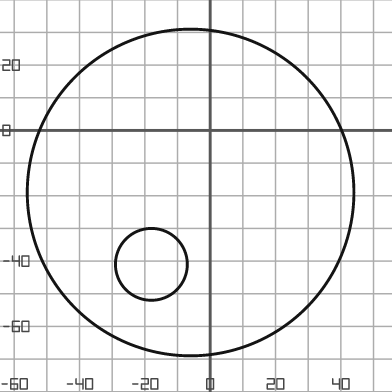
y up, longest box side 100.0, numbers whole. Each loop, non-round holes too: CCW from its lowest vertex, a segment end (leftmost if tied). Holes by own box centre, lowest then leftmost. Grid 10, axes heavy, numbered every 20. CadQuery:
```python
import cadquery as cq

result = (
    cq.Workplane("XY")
    .moveTo(-6.0, -19.0)
    .circle(50.0)
    .moveTo(-18.0, -41.0)
    .circle(11.0)
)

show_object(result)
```